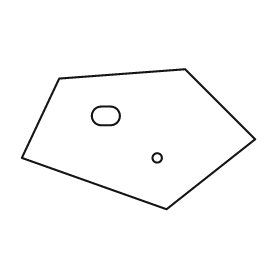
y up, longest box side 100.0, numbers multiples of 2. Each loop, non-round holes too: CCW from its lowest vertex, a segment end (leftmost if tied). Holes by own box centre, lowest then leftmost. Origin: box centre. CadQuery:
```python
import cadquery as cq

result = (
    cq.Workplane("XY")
    .moveTo(12.0, -30.0)
    .lineTo(50.0, 0.0)
    .lineTo(20.0, 30.0)
    .lineTo(-34.0, 26.0)
    .lineTo(-50.0, -8.0)
    .close()
    .moveTo(8.0, -8.0)
    .circle(2.0)
    .moveTo(-16.0, 6.0)
    .lineTo(-12.0, 6.0)
    .threePointArc((-8.0, 10.0), (-12.0, 14.0))
    .lineTo(-16.0, 14.0)
    .threePointArc((-20.0, 10.0), (-16.0, 6.0))
    .close()
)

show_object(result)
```